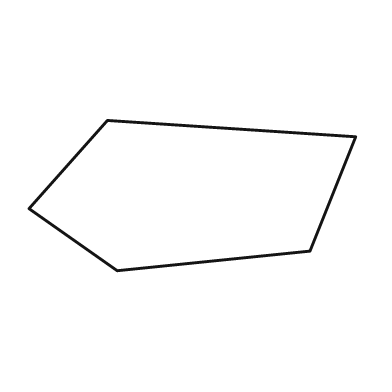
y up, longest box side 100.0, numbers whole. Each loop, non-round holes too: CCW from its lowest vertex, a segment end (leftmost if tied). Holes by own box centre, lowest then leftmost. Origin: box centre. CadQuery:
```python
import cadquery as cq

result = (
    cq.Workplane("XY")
    .moveTo(-23.0, -23.0)
    .lineTo(36.0, -17.0)
    .lineTo(50.0, 18.0)
    .lineTo(-26.0, 23.0)
    .lineTo(-50.0, -4.0)
    .close()
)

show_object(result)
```